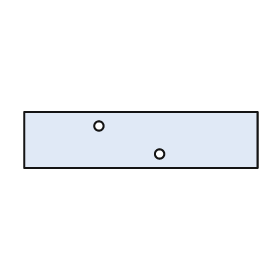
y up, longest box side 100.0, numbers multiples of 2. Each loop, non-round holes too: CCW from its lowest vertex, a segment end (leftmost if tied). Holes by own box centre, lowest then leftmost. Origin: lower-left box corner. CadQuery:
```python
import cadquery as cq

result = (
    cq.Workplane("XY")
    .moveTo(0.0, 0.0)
    .lineTo(100.0, 0.0)
    .lineTo(100.0, 24.0)
    .lineTo(0.0, 24.0)
    .close()
    .moveTo(58.0, 6.0)
    .circle(2.0)
    .moveTo(32.0, 18.0)
    .circle(2.0)
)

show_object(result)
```